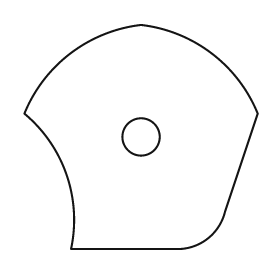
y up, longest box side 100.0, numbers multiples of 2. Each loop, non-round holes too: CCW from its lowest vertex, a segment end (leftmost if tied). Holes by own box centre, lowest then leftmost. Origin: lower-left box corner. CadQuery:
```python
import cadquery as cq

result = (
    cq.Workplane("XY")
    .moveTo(20.0, 0.0)
    .lineTo(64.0, 0.0)
    .threePointArc((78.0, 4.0), (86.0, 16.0))
    .lineTo(100.0, 58.0)
    .threePointArc((80.0, 84.0), (50.0, 96.0))
    .threePointArc((20.0, 84.0), (0.0, 58.0))
    .threePointArc((18.0, 32.0), (20.0, 0.0))
    .close()
    .moveTo(50.0, 48.0)
    .circle(8.0)
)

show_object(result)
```